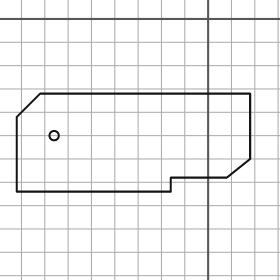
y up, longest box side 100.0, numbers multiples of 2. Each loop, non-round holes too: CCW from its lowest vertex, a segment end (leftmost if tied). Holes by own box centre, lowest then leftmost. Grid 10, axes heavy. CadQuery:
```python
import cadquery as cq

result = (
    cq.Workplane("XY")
    .moveTo(-82.0, -74.0)
    .lineTo(-16.0, -74.0)
    .lineTo(-16.0, -68.0)
    .lineTo(8.0, -68.0)
    .lineTo(18.0, -60.0)
    .lineTo(18.0, -32.0)
    .lineTo(-72.0, -32.0)
    .lineTo(-82.0, -42.0)
    .close()
    .moveTo(-66.0, -50.0)
    .circle(2.0)
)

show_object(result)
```